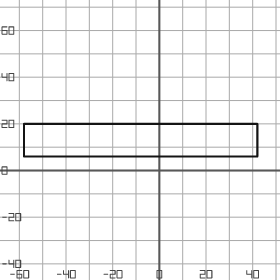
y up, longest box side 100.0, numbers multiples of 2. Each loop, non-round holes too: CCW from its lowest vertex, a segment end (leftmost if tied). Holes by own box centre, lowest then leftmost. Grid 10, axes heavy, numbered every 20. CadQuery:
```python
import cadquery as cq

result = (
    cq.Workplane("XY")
    .moveTo(-58.0, 6.0)
    .lineTo(42.0, 6.0)
    .lineTo(42.0, 20.0)
    .lineTo(-58.0, 20.0)
    .close()
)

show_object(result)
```